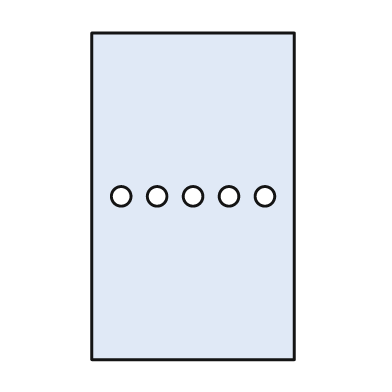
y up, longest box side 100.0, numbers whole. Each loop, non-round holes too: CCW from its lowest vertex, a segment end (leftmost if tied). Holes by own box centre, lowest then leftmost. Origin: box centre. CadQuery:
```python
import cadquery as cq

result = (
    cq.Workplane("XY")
    .moveTo(-31.0, -50.0)
    .lineTo(31.0, -50.0)
    .lineTo(31.0, 50.0)
    .lineTo(-31.0, 50.0)
    .close()
    .moveTo(-22.0, 0.0)
    .circle(3.0)
    .moveTo(-11.0, 0.0)
    .circle(3.0)
    .moveTo(0.0, 0.0)
    .circle(3.0)
    .moveTo(11.0, 0.0)
    .circle(3.0)
    .moveTo(22.0, 0.0)
    .circle(3.0)
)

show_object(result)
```